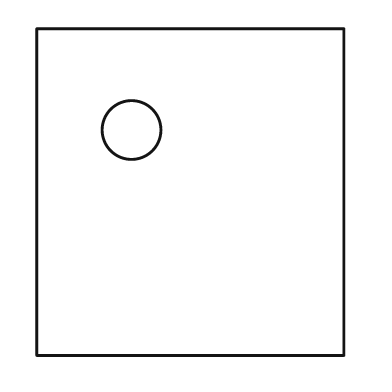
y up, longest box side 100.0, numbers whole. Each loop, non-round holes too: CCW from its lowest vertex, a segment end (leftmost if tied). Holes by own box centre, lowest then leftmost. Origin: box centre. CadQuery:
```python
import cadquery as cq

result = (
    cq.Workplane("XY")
    .moveTo(-47.0, -50.0)
    .lineTo(47.0, -50.0)
    .lineTo(47.0, 50.0)
    .lineTo(-47.0, 50.0)
    .close()
    .moveTo(-18.0, 19.0)
    .circle(9.0)
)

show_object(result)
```